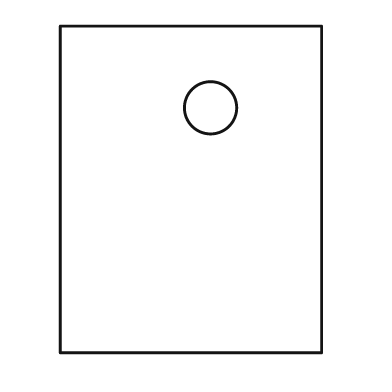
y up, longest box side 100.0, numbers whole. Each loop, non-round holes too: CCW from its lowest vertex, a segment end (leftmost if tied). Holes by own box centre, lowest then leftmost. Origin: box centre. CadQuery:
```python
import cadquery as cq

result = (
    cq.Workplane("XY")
    .moveTo(-40.0, -50.0)
    .lineTo(40.0, -50.0)
    .lineTo(40.0, 50.0)
    .lineTo(-40.0, 50.0)
    .close()
    .moveTo(6.0, 25.0)
    .circle(8.0)
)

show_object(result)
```